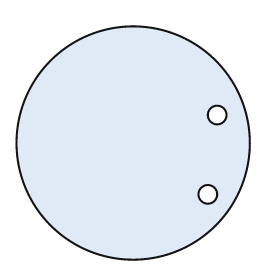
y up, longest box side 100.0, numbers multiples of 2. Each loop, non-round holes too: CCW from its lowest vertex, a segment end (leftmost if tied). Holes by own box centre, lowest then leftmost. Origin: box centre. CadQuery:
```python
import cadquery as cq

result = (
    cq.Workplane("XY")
    .moveTo(0.0, 0.0)
    .circle(50.0)
    .moveTo(32.0, -22.0)
    .circle(4.0)
    .moveTo(36.0, 12.0)
    .circle(4.0)
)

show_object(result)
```